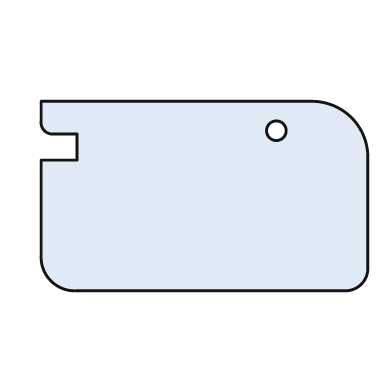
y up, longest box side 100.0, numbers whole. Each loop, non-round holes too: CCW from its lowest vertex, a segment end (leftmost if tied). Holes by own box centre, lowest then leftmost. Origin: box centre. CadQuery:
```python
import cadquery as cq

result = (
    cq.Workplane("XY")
    .moveTo(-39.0, -29.0)
    .lineTo(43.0, -29.0)
    .threePointArc((48.0, -27.0), (50.0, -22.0))
    .lineTo(50.0, 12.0)
    .threePointArc((45.0, 24.0), (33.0, 29.0))
    .lineTo(-50.0, 29.0)
    .lineTo(-50.0, 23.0)
    .threePointArc((-49.0, 20.0), (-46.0, 19.0))
    .lineTo(-39.0, 19.0)
    .lineTo(-39.0, 11.0)
    .lineTo(-50.0, 11.0)
    .lineTo(-50.0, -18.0)
    .threePointArc((-47.0, -26.0), (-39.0, -29.0))
    .close()
    .moveTo(22.0, 20.0)
    .circle(3.0)
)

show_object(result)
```